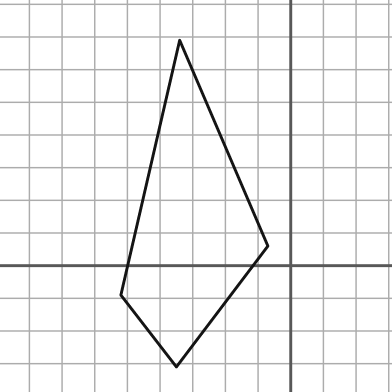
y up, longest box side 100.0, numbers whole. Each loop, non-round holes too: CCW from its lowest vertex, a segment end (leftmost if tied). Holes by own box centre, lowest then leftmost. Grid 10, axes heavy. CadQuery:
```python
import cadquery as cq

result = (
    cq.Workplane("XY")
    .moveTo(-35.0, -31.0)
    .lineTo(-7.0, 6.0)
    .lineTo(-34.0, 69.0)
    .lineTo(-52.0, -9.0)
    .close()
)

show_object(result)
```